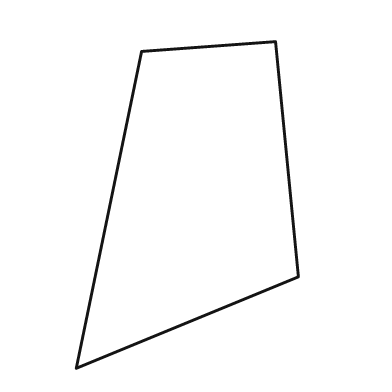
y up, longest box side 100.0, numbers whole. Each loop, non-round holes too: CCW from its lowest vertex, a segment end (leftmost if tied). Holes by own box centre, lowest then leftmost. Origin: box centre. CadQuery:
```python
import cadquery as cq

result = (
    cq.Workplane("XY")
    .moveTo(-34.0, -50.0)
    .lineTo(34.0, -22.0)
    .lineTo(27.0, 50.0)
    .lineTo(-14.0, 47.0)
    .close()
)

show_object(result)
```